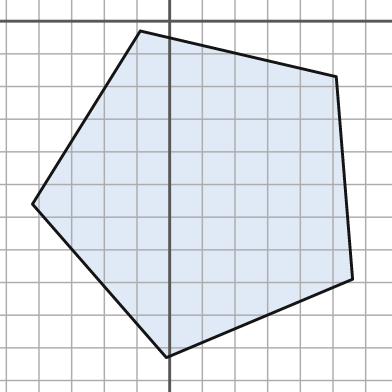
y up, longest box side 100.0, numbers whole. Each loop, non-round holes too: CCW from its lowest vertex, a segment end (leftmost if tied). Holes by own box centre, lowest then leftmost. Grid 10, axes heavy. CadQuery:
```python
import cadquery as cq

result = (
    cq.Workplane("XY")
    .moveTo(-1.0, -103.0)
    .lineTo(56.0, -79.0)
    .lineTo(51.0, -17.0)
    .lineTo(-9.0, -3.0)
    .lineTo(-42.0, -56.0)
    .close()
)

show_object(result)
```